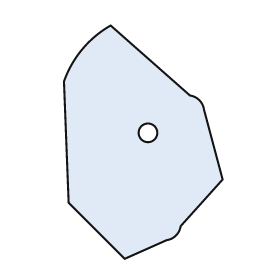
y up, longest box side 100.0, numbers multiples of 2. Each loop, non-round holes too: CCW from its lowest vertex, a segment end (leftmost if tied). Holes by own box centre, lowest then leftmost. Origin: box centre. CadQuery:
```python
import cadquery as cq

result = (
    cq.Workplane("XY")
    .moveTo(-8.0, -50.0)
    .lineTo(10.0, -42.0)
    .threePointArc((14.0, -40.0), (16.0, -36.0))
    .lineTo(34.0, -16.0)
    .lineTo(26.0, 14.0)
    .threePointArc((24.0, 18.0), (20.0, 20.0))
    .lineTo(-14.0, 50.0)
    .threePointArc((-26.0, 40.0), (-34.0, 26.0))
    .lineTo(-32.0, -26.0)
    .close()
    .moveTo(2.0, 4.0)
    .circle(4.0)
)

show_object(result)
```